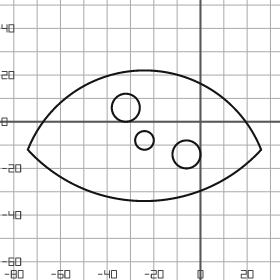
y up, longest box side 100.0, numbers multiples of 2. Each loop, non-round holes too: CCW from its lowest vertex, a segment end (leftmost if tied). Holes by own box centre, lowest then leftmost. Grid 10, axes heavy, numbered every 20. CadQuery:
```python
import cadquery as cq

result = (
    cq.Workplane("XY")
    .moveTo(-74.0, -12.0)
    .threePointArc((-24.0, -34.0), (26.0, -12.0))
    .threePointArc((-24.0, 22.0), (-74.0, -12.0))
    .close()
    .moveTo(-6.0, -14.0)
    .circle(6.0)
    .moveTo(-24.0, -8.0)
    .circle(4.0)
    .moveTo(-32.0, 6.0)
    .circle(6.0)
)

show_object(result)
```